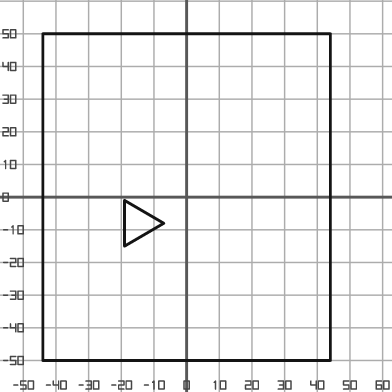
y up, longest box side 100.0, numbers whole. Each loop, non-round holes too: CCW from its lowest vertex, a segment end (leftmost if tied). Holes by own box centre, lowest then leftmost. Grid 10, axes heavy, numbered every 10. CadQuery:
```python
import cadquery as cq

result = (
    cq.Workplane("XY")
    .moveTo(-44.0, -50.0)
    .lineTo(44.0, -50.0)
    .lineTo(44.0, 50.0)
    .lineTo(-44.0, 50.0)
    .close()
    .moveTo(-19.0, -15.0)
    .lineTo(-7.0, -8.0)
    .lineTo(-19.0, -1.0)
    .close()
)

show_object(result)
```